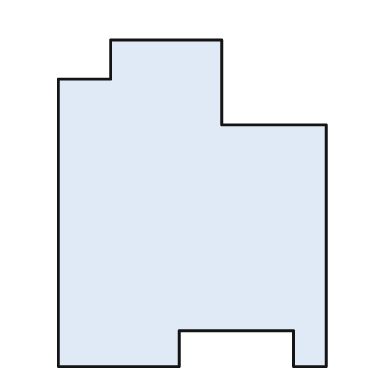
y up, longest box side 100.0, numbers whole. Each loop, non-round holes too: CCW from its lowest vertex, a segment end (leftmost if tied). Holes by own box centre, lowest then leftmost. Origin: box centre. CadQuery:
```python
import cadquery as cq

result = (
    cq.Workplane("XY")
    .moveTo(-41.0, -50.0)
    .lineTo(-4.0, -50.0)
    .lineTo(-4.0, -39.0)
    .lineTo(31.0, -39.0)
    .lineTo(31.0, -50.0)
    .lineTo(41.0, -50.0)
    .lineTo(41.0, 24.0)
    .lineTo(9.0, 24.0)
    .lineTo(9.0, 50.0)
    .lineTo(-25.0, 50.0)
    .lineTo(-25.0, 38.0)
    .lineTo(-41.0, 38.0)
    .close()
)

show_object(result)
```